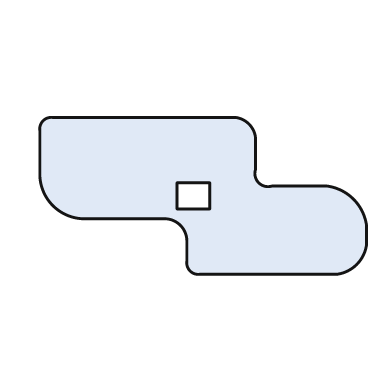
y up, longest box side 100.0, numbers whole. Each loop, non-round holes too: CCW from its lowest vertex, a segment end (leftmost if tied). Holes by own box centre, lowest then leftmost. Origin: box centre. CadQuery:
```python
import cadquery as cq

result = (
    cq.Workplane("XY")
    .moveTo(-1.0, -24.0)
    .lineTo(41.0, -24.0)
    .threePointArc((47.0, -21.0), (50.0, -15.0))
    .lineTo(50.0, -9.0)
    .threePointArc((46.0, -1.0), (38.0, 3.0))
    .lineTo(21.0, 3.0)
    .threePointArc((17.0, 4.0), (16.0, 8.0))
    .lineTo(16.0, 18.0)
    .threePointArc((14.0, 22.0), (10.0, 24.0))
    .lineTo(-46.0, 24.0)
    .threePointArc((-49.0, 23.0), (-50.0, 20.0))
    .lineTo(-50.0, 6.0)
    .threePointArc((-46.0, -3.0), (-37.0, -7.0))
    .lineTo(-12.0, -7.0)
    .threePointArc((-7.0, -9.0), (-5.0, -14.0))
    .lineTo(-5.0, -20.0)
    .threePointArc((-4.0, -23.0), (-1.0, -24.0))
    .close()
    .moveTo(-8.0, -4.0)
    .lineTo(2.0, -4.0)
    .lineTo(2.0, 4.0)
    .lineTo(-8.0, 4.0)
    .close()
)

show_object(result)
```